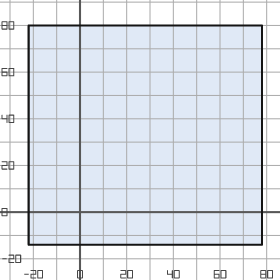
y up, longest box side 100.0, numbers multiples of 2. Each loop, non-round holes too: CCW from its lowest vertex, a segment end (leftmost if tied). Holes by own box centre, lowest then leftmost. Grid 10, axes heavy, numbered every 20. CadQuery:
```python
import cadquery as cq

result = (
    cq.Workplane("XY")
    .moveTo(-22.0, -14.0)
    .lineTo(78.0, -14.0)
    .lineTo(78.0, 80.0)
    .lineTo(-22.0, 80.0)
    .close()
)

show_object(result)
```